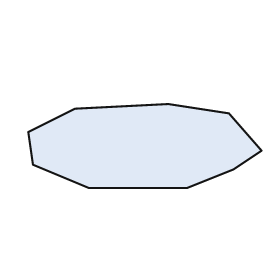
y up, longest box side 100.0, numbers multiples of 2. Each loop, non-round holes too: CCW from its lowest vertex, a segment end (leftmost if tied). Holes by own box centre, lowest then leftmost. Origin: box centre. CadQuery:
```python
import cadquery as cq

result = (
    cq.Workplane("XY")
    .moveTo(-24.0, -18.0)
    .lineTo(18.0, -18.0)
    .lineTo(38.0, -10.0)
    .lineTo(50.0, -2.0)
    .lineTo(36.0, 14.0)
    .lineTo(10.0, 18.0)
    .lineTo(-30.0, 16.0)
    .lineTo(-50.0, 6.0)
    .lineTo(-48.0, -8.0)
    .close()
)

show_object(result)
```